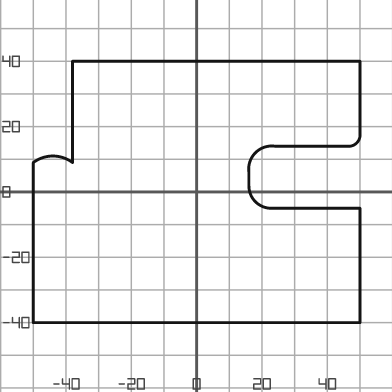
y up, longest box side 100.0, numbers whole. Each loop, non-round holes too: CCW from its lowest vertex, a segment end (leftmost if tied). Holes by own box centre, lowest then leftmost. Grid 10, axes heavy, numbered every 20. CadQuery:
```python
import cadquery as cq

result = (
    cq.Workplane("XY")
    .moveTo(-50.0, -40.0)
    .lineTo(50.0, -40.0)
    .lineTo(50.0, -5.0)
    .lineTo(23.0, -5.0)
    .threePointArc((18.0, -3.0), (16.0, 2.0))
    .lineTo(16.0, 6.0)
    .threePointArc((18.0, 12.0), (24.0, 14.0))
    .lineTo(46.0, 14.0)
    .threePointArc((49.0, 15.0), (50.0, 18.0))
    .lineTo(50.0, 40.0)
    .lineTo(-38.0, 40.0)
    .lineTo(-38.0, 9.0)
    .threePointArc((-44.0, 11.0), (-50.0, 9.0))
    .close()
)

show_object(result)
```